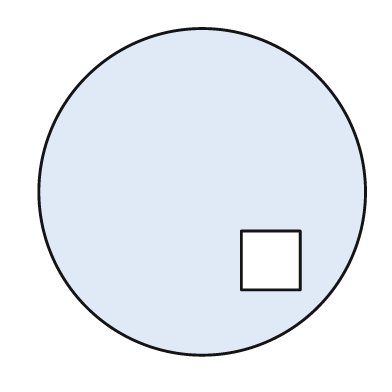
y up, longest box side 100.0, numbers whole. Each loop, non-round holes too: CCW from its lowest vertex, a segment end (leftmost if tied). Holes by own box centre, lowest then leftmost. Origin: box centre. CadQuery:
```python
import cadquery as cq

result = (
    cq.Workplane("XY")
    .moveTo(0.0, 0.0)
    .circle(50.0)
    .moveTo(12.0, -30.0)
    .lineTo(30.0, -30.0)
    .lineTo(30.0, -12.0)
    .lineTo(12.0, -12.0)
    .close()
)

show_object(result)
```